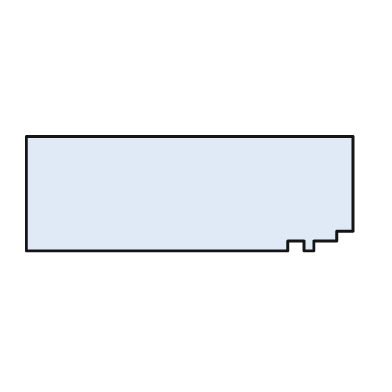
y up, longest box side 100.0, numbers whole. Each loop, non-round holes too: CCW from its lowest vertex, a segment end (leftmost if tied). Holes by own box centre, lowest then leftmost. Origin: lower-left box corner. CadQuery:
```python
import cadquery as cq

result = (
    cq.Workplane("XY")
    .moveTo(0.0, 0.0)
    .lineTo(80.0, 0.0)
    .lineTo(80.0, 3.0)
    .lineTo(85.0, 3.0)
    .lineTo(85.0, 0.0)
    .lineTo(88.0, 0.0)
    .lineTo(88.0, 3.0)
    .lineTo(95.0, 3.0)
    .lineTo(95.0, 6.0)
    .lineTo(100.0, 6.0)
    .lineTo(100.0, 35.0)
    .lineTo(0.0, 35.0)
    .close()
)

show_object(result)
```